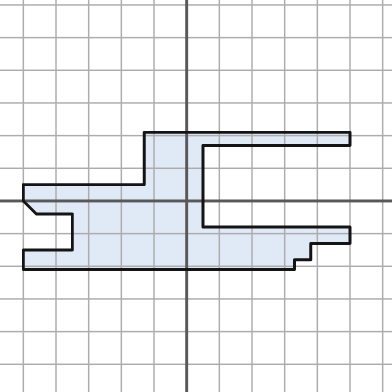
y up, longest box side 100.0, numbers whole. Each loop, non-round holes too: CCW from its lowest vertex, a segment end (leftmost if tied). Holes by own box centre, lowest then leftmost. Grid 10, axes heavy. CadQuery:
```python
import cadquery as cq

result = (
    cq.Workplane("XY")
    .moveTo(-50.0, -21.0)
    .lineTo(33.0, -21.0)
    .lineTo(33.0, -18.0)
    .lineTo(38.0, -18.0)
    .lineTo(38.0, -13.0)
    .lineTo(50.0, -13.0)
    .lineTo(50.0, -8.0)
    .lineTo(5.0, -8.0)
    .lineTo(5.0, 17.0)
    .lineTo(50.0, 17.0)
    .lineTo(50.0, 21.0)
    .lineTo(-13.0, 21.0)
    .lineTo(-13.0, 5.0)
    .lineTo(-50.0, 5.0)
    .lineTo(-50.0, 0.0)
    .lineTo(-46.0, -4.0)
    .lineTo(-35.0, -4.0)
    .lineTo(-35.0, -15.0)
    .lineTo(-50.0, -15.0)
    .close()
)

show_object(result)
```